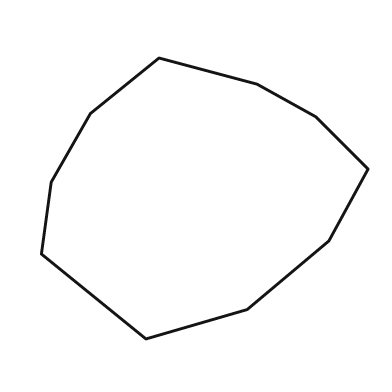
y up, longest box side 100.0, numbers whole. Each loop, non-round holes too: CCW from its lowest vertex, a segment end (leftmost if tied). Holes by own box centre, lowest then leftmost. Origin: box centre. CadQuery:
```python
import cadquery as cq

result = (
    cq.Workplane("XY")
    .moveTo(-18.0, -43.0)
    .lineTo(13.0, -34.0)
    .lineTo(38.0, -13.0)
    .lineTo(50.0, 9.0)
    .lineTo(34.0, 25.0)
    .lineTo(16.0, 35.0)
    .lineTo(-14.0, 43.0)
    .lineTo(-35.0, 26.0)
    .lineTo(-47.0, 5.0)
    .lineTo(-50.0, -17.0)
    .close()
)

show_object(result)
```